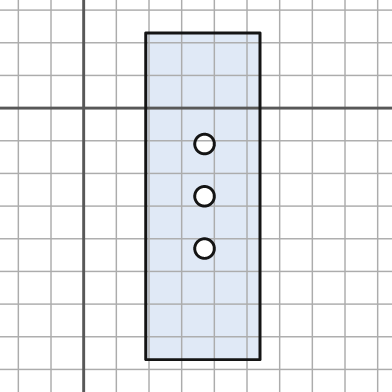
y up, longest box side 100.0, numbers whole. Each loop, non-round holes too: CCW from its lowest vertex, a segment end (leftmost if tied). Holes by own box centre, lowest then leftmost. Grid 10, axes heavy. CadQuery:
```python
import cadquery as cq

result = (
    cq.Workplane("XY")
    .moveTo(19.0, -77.0)
    .lineTo(54.0, -77.0)
    .lineTo(54.0, 23.0)
    .lineTo(19.0, 23.0)
    .close()
    .moveTo(37.0, -43.0)
    .circle(3.0)
    .moveTo(37.0, -27.0)
    .circle(3.0)
    .moveTo(37.0, -11.0)
    .circle(3.0)
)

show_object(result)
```